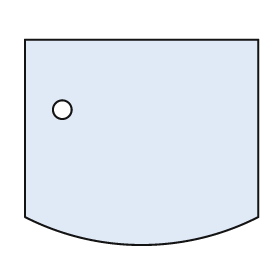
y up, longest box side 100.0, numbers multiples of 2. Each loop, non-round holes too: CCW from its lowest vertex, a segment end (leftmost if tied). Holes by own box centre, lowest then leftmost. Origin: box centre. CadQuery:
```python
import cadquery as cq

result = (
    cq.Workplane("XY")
    .moveTo(-50.0, -32.0)
    .threePointArc((0.0, -44.0), (50.0, -32.0))
    .lineTo(50.0, 44.0)
    .lineTo(-50.0, 44.0)
    .close()
    .moveTo(-34.0, 14.0)
    .circle(4.0)
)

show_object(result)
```